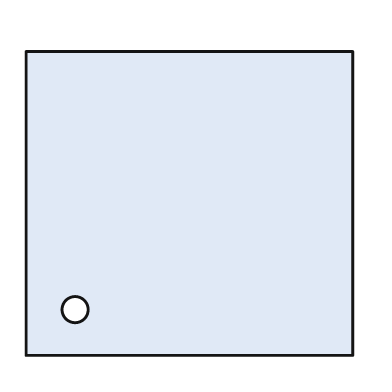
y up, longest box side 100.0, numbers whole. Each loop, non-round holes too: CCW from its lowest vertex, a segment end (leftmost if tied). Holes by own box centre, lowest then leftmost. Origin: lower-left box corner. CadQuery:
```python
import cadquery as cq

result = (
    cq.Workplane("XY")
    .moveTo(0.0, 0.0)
    .lineTo(100.0, 0.0)
    .lineTo(100.0, 93.0)
    .lineTo(0.0, 93.0)
    .close()
    .moveTo(15.0, 14.0)
    .circle(4.0)
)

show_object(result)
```